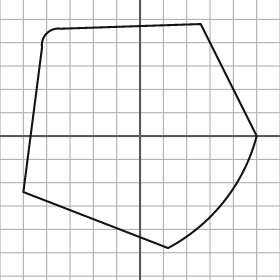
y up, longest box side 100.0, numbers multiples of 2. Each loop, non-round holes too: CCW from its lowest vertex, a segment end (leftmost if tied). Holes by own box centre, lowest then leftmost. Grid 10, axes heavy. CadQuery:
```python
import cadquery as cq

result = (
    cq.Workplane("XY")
    .moveTo(12.0, -48.0)
    .threePointArc((36.0, -28.0), (50.0, 0.0))
    .lineTo(26.0, 48.0)
    .lineTo(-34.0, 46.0)
    .threePointArc((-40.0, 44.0), (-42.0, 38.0))
    .lineTo(-50.0, -24.0)
    .close()
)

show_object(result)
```